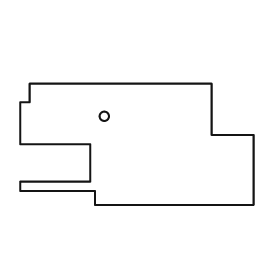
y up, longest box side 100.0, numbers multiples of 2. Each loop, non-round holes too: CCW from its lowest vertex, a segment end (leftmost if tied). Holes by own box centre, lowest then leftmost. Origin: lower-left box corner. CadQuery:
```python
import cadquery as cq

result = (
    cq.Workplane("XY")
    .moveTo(32.0, 0.0)
    .lineTo(100.0, 0.0)
    .lineTo(100.0, 30.0)
    .lineTo(82.0, 30.0)
    .lineTo(82.0, 52.0)
    .lineTo(4.0, 52.0)
    .lineTo(4.0, 44.0)
    .lineTo(0.0, 44.0)
    .lineTo(0.0, 26.0)
    .lineTo(30.0, 26.0)
    .lineTo(30.0, 10.0)
    .lineTo(0.0, 10.0)
    .lineTo(0.0, 6.0)
    .lineTo(32.0, 6.0)
    .close()
    .moveTo(36.0, 38.0)
    .circle(2.0)
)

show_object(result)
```